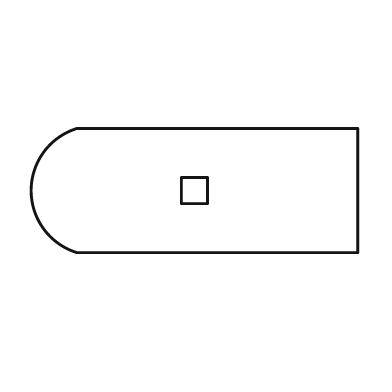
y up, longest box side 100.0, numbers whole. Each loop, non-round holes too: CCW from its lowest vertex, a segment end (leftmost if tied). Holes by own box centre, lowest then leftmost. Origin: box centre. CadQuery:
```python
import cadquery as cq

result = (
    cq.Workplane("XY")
    .moveTo(-36.0, -19.0)
    .lineTo(50.0, -19.0)
    .lineTo(50.0, 19.0)
    .lineTo(-36.0, 19.0)
    .threePointArc((-50.0, 0.0), (-36.0, -19.0))
    .close()
    .moveTo(-4.0, -4.0)
    .lineTo(4.0, -4.0)
    .lineTo(4.0, 4.0)
    .lineTo(-4.0, 4.0)
    .close()
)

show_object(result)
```